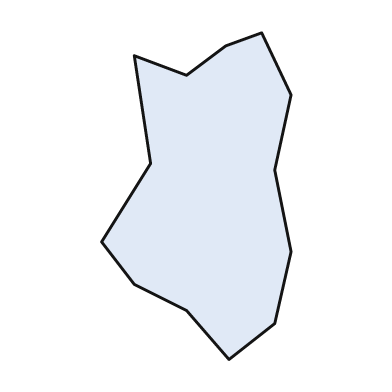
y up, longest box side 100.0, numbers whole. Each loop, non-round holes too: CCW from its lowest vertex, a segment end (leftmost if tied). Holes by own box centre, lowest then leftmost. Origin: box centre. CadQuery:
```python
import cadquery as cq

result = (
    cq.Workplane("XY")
    .moveTo(10.0, -50.0)
    .lineTo(24.0, -39.0)
    .lineTo(29.0, -17.0)
    .lineTo(24.0, 8.0)
    .lineTo(29.0, 31.0)
    .lineTo(20.0, 50.0)
    .lineTo(9.0, 46.0)
    .lineTo(-3.0, 37.0)
    .lineTo(-19.0, 43.0)
    .lineTo(-14.0, 10.0)
    .lineTo(-29.0, -14.0)
    .lineTo(-19.0, -27.0)
    .lineTo(-3.0, -35.0)
    .close()
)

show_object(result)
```